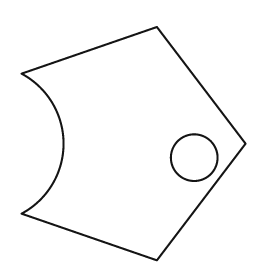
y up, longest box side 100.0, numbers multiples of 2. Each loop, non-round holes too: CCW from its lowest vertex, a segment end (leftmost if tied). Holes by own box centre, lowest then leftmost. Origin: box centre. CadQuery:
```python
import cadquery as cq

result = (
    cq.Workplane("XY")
    .moveTo(10.0, -50.0)
    .lineTo(48.0, 0.0)
    .lineTo(10.0, 50.0)
    .lineTo(-48.0, 30.0)
    .threePointArc((-30.0, 0.0), (-48.0, -30.0))
    .close()
    .moveTo(26.0, -6.0)
    .circle(10.0)
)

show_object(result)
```